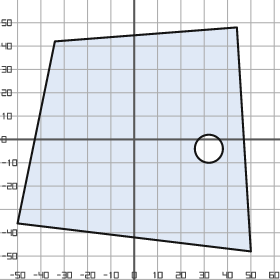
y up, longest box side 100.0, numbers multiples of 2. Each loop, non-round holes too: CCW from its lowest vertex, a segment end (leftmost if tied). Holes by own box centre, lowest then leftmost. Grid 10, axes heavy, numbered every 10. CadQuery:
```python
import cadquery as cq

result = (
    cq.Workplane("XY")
    .moveTo(50.0, -48.0)
    .lineTo(44.0, 48.0)
    .lineTo(-34.0, 42.0)
    .lineTo(-50.0, -36.0)
    .close()
    .moveTo(32.0, -4.0)
    .circle(6.0)
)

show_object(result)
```